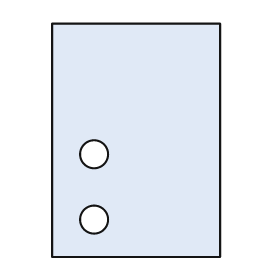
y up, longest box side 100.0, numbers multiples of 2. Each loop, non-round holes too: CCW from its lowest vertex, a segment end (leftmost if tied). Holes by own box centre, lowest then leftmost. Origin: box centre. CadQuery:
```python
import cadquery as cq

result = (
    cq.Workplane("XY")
    .moveTo(-36.0, -50.0)
    .lineTo(36.0, -50.0)
    .lineTo(36.0, 50.0)
    .lineTo(-36.0, 50.0)
    .close()
    .moveTo(-18.0, -34.0)
    .circle(6.0)
    .moveTo(-18.0, -6.0)
    .circle(6.0)
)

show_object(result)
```